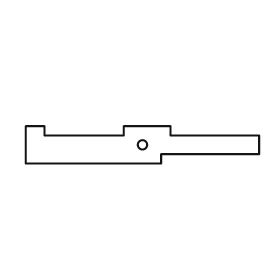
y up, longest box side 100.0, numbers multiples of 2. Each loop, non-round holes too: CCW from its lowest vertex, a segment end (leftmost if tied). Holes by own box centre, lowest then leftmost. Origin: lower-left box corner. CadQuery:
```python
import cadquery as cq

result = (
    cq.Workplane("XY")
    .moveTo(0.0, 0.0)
    .lineTo(58.0, 0.0)
    .lineTo(58.0, 4.0)
    .lineTo(100.0, 4.0)
    .lineTo(100.0, 12.0)
    .lineTo(62.0, 12.0)
    .lineTo(62.0, 16.0)
    .lineTo(42.0, 16.0)
    .lineTo(42.0, 12.0)
    .lineTo(8.0, 12.0)
    .lineTo(8.0, 16.0)
    .lineTo(0.0, 16.0)
    .close()
    .moveTo(50.0, 8.0)
    .circle(2.0)
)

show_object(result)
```